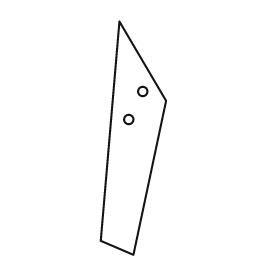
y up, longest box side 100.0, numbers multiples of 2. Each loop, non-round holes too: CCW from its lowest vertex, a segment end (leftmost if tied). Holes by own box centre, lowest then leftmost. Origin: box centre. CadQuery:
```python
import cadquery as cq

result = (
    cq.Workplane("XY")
    .moveTo(0.0, -50.0)
    .lineTo(14.0, 16.0)
    .lineTo(-6.0, 50.0)
    .lineTo(-14.0, -44.0)
    .close()
    .moveTo(-2.0, 8.0)
    .circle(2.0)
    .moveTo(4.0, 20.0)
    .circle(2.0)
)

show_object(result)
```